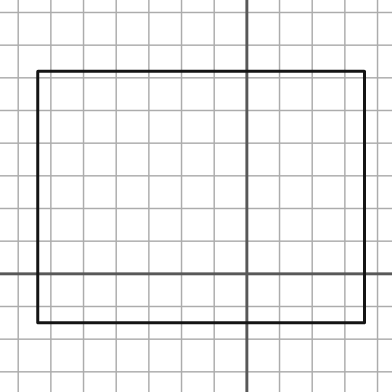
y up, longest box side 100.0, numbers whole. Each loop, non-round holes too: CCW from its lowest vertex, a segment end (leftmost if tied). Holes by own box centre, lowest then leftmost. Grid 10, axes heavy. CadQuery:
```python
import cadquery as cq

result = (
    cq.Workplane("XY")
    .moveTo(-64.0, -15.0)
    .lineTo(36.0, -15.0)
    .lineTo(36.0, 62.0)
    .lineTo(-64.0, 62.0)
    .close()
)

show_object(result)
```